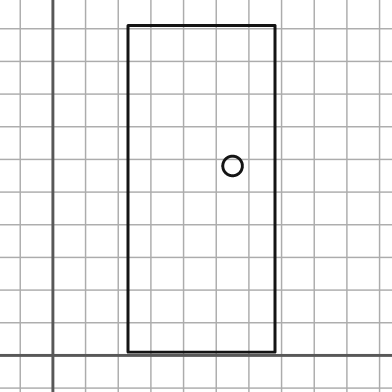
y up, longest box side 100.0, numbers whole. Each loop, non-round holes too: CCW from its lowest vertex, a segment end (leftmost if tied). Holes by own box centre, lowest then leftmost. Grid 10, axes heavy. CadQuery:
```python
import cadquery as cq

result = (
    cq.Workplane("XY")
    .moveTo(23.0, 1.0)
    .lineTo(68.0, 1.0)
    .lineTo(68.0, 101.0)
    .lineTo(23.0, 101.0)
    .close()
    .moveTo(55.0, 58.0)
    .circle(3.0)
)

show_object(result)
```